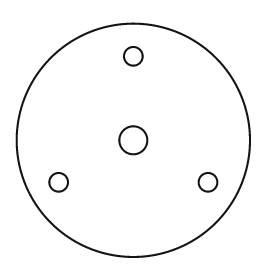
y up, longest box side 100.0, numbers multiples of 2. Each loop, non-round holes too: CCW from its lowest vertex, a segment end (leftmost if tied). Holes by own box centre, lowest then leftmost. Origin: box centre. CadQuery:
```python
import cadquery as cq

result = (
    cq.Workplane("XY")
    .moveTo(0.0, 0.0)
    .circle(50.0)
    .moveTo(-32.0, -18.0)
    .circle(4.0)
    .moveTo(32.0, -18.0)
    .circle(4.0)
    .moveTo(0.0, 0.0)
    .circle(6.0)
    .moveTo(0.0, 36.0)
    .circle(4.0)
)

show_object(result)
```